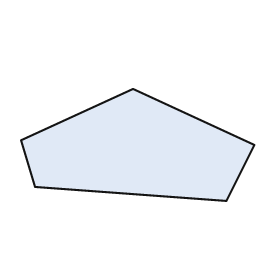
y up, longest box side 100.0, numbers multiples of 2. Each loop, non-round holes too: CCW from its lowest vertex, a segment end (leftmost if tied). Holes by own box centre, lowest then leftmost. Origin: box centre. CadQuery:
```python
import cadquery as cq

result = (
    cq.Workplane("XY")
    .moveTo(38.0, -24.0)
    .lineTo(50.0, 0.0)
    .lineTo(-2.0, 24.0)
    .lineTo(-50.0, 2.0)
    .lineTo(-44.0, -18.0)
    .close()
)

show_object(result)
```